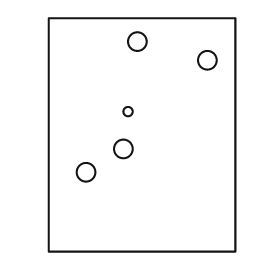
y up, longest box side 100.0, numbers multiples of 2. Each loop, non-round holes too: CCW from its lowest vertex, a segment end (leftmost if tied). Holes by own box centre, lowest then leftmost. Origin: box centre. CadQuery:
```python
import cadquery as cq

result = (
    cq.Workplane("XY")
    .moveTo(-40.0, -50.0)
    .lineTo(40.0, -50.0)
    .lineTo(40.0, 50.0)
    .lineTo(-40.0, 50.0)
    .close()
    .moveTo(-24.0, -16.0)
    .circle(4.0)
    .moveTo(-8.0, -6.0)
    .circle(4.0)
    .moveTo(-6.0, 10.0)
    .circle(2.0)
    .moveTo(28.0, 32.0)
    .circle(4.0)
    .moveTo(-2.0, 40.0)
    .circle(4.0)
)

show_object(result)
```